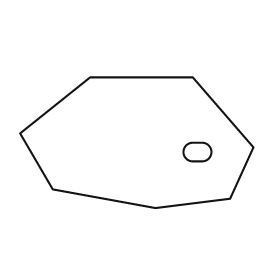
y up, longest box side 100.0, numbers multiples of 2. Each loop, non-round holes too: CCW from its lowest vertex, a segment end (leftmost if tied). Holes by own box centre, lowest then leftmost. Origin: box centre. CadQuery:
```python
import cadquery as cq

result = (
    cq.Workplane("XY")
    .moveTo(8.0, -28.0)
    .lineTo(40.0, -24.0)
    .lineTo(50.0, -2.0)
    .lineTo(24.0, 28.0)
    .lineTo(-20.0, 28.0)
    .lineTo(-50.0, 4.0)
    .lineTo(-36.0, -20.0)
    .close()
    .moveTo(24.0, -8.0)
    .lineTo(28.0, -8.0)
    .threePointArc((32.0, -4.0), (28.0, 0.0))
    .lineTo(24.0, 0.0)
    .threePointArc((20.0, -4.0), (24.0, -8.0))
    .close()
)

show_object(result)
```